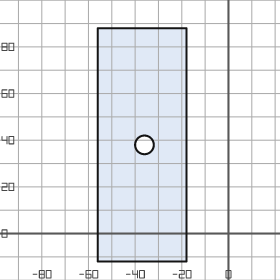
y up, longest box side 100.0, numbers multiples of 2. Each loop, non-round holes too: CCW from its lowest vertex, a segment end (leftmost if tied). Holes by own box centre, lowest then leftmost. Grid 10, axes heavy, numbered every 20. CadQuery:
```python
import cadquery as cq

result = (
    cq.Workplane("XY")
    .moveTo(-56.0, -12.0)
    .lineTo(-18.0, -12.0)
    .lineTo(-18.0, 88.0)
    .lineTo(-56.0, 88.0)
    .close()
    .moveTo(-36.0, 38.0)
    .circle(4.0)
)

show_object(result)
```